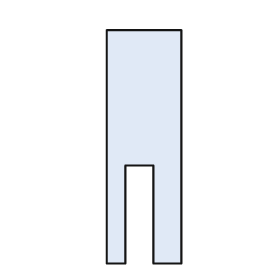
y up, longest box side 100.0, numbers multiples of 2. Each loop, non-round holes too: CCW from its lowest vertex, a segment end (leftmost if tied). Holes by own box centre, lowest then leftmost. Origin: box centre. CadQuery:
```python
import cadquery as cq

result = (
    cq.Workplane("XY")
    .moveTo(-16.0, -50.0)
    .lineTo(-8.0, -50.0)
    .lineTo(-8.0, -8.0)
    .lineTo(4.0, -8.0)
    .lineTo(4.0, -50.0)
    .lineTo(16.0, -50.0)
    .lineTo(16.0, 50.0)
    .lineTo(-16.0, 50.0)
    .close()
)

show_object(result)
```